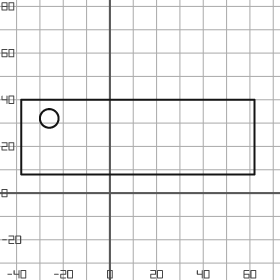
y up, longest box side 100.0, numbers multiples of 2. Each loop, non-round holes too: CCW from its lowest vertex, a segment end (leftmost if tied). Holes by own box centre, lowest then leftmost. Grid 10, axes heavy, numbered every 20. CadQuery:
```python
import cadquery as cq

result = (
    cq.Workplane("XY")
    .moveTo(-38.0, 8.0)
    .lineTo(62.0, 8.0)
    .lineTo(62.0, 40.0)
    .lineTo(-38.0, 40.0)
    .close()
    .moveTo(-26.0, 32.0)
    .circle(4.0)
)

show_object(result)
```